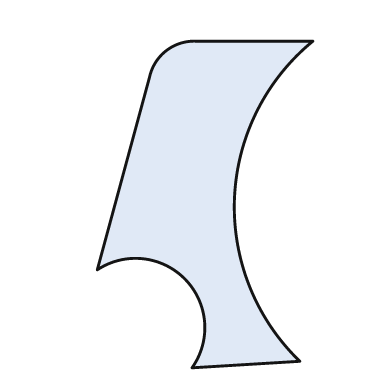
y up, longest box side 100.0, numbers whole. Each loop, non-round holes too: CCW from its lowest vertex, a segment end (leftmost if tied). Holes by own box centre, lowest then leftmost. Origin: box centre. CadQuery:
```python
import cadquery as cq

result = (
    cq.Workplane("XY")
    .moveTo(-4.0, -50.0)
    .lineTo(29.0, -48.0)
    .threePointArc((9.0, 2.0), (33.0, 50.0))
    .lineTo(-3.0, 50.0)
    .threePointArc((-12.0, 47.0), (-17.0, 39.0))
    .lineTo(-33.0, -20.0)
    .threePointArc((-6.0, -23.0), (-4.0, -50.0))
    .close()
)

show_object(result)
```